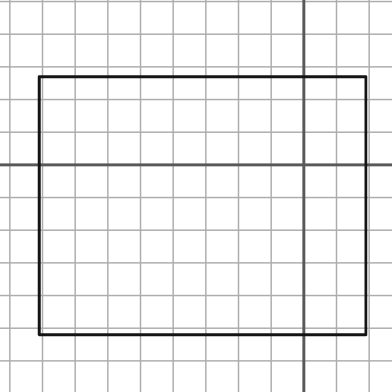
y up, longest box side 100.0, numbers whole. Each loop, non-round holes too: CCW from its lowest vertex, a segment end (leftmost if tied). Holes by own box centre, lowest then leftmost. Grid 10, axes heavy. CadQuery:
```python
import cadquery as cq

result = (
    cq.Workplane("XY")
    .moveTo(-81.0, -52.0)
    .lineTo(19.0, -52.0)
    .lineTo(19.0, 27.0)
    .lineTo(-81.0, 27.0)
    .close()
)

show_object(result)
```